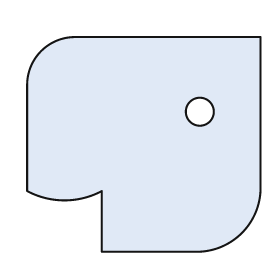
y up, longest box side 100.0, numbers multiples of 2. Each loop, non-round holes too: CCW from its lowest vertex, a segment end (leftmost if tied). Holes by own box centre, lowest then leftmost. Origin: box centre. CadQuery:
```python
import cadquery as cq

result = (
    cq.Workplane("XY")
    .moveTo(-18.0, -46.0)
    .lineTo(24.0, -46.0)
    .threePointArc((42.0, -38.0), (50.0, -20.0))
    .lineTo(50.0, 46.0)
    .lineTo(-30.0, 46.0)
    .threePointArc((-44.0, 40.0), (-50.0, 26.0))
    .lineTo(-50.0, -20.0)
    .threePointArc((-34.0, -24.0), (-18.0, -20.0))
    .close()
    .moveTo(24.0, 14.0)
    .circle(6.0)
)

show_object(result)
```